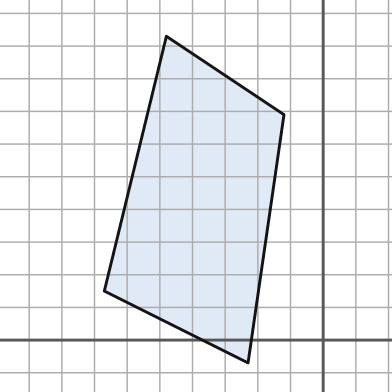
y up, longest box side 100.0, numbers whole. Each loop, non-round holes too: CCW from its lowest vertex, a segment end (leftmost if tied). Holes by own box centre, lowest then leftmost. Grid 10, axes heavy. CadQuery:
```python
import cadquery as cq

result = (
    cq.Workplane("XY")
    .moveTo(-23.0, -7.0)
    .lineTo(-12.0, 69.0)
    .lineTo(-48.0, 93.0)
    .lineTo(-67.0, 15.0)
    .close()
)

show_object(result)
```